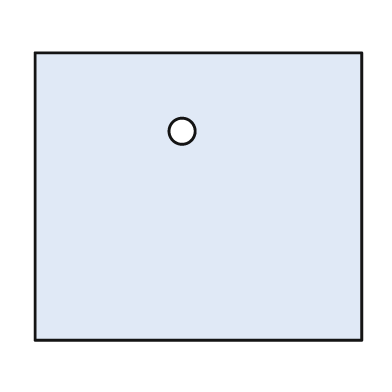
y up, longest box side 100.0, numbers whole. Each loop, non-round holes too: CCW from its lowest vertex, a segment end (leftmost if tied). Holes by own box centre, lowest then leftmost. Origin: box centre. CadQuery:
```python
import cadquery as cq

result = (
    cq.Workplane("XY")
    .moveTo(-50.0, -44.0)
    .lineTo(50.0, -44.0)
    .lineTo(50.0, 44.0)
    .lineTo(-50.0, 44.0)
    .close()
    .moveTo(-5.0, 20.0)
    .circle(4.0)
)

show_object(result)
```